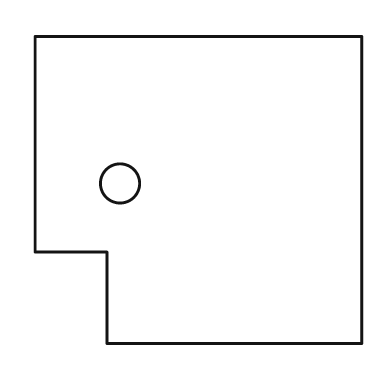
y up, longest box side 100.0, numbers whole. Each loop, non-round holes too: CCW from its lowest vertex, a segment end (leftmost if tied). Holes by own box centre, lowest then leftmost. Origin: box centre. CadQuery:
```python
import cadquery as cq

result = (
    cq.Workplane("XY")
    .moveTo(-28.0, -47.0)
    .lineTo(50.0, -47.0)
    .lineTo(50.0, 47.0)
    .lineTo(-50.0, 47.0)
    .lineTo(-50.0, -19.0)
    .lineTo(-28.0, -19.0)
    .close()
    .moveTo(-24.0, 2.0)
    .circle(6.0)
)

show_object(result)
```